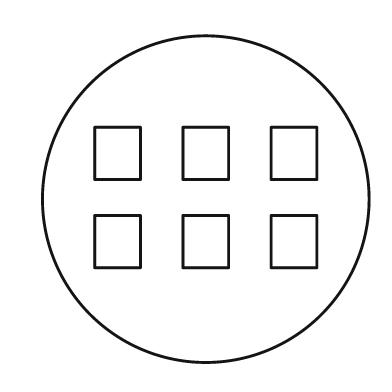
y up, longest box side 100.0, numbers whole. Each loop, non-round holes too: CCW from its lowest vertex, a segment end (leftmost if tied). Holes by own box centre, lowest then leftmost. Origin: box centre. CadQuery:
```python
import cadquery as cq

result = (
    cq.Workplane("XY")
    .moveTo(0.0, 0.0)
    .circle(50.0)
    .moveTo(-34.0, -21.0)
    .lineTo(-20.0, -21.0)
    .lineTo(-20.0, -5.0)
    .lineTo(-34.0, -5.0)
    .close()
    .moveTo(-7.0, -21.0)
    .lineTo(7.0, -21.0)
    .lineTo(7.0, -5.0)
    .lineTo(-7.0, -5.0)
    .close()
    .moveTo(20.0, -21.0)
    .lineTo(34.0, -21.0)
    .lineTo(34.0, -5.0)
    .lineTo(20.0, -5.0)
    .close()
    .moveTo(-34.0, 6.0)
    .lineTo(-20.0, 6.0)
    .lineTo(-20.0, 22.0)
    .lineTo(-34.0, 22.0)
    .close()
    .moveTo(-7.0, 6.0)
    .lineTo(7.0, 6.0)
    .lineTo(7.0, 22.0)
    .lineTo(-7.0, 22.0)
    .close()
    .moveTo(20.0, 6.0)
    .lineTo(34.0, 6.0)
    .lineTo(34.0, 22.0)
    .lineTo(20.0, 22.0)
    .close()
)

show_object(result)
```